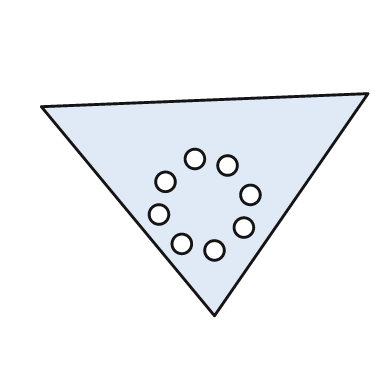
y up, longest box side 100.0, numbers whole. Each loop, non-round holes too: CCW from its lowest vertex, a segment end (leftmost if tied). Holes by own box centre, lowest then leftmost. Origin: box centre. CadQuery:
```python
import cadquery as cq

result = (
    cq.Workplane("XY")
    .moveTo(3.0, -34.0)
    .lineTo(50.0, 34.0)
    .lineTo(-50.0, 30.0)
    .close()
    .moveTo(3.0, -14.0)
    .circle(3.0)
    .moveTo(-7.0, -12.0)
    .circle(3.0)
    .moveTo(12.0, -7.0)
    .circle(3.0)
    .moveTo(-14.0, -3.0)
    .circle(3.0)
    .moveTo(14.0, 3.0)
    .circle(3.0)
    .moveTo(-12.0, 7.0)
    .circle(3.0)
    .moveTo(7.0, 12.0)
    .circle(3.0)
    .moveTo(-3.0, 14.0)
    .circle(3.0)
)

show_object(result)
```